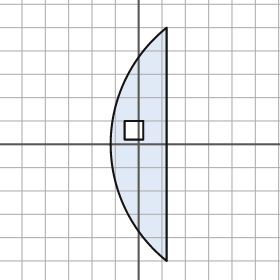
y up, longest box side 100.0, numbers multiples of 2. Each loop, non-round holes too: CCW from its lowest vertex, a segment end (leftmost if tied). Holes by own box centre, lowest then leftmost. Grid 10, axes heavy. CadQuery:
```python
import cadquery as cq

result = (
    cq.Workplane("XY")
    .moveTo(12.0, -50.0)
    .lineTo(12.0, 50.0)
    .threePointArc((-12.0, 0.0), (12.0, -50.0))
    .close()
    .moveTo(-6.0, 2.0)
    .lineTo(2.0, 2.0)
    .lineTo(2.0, 10.0)
    .lineTo(-6.0, 10.0)
    .close()
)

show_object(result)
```